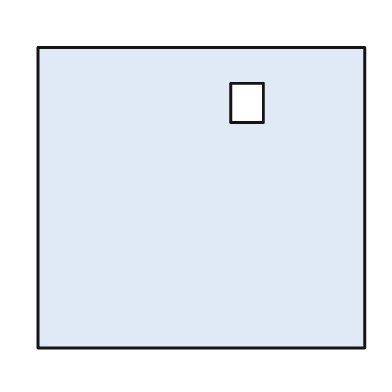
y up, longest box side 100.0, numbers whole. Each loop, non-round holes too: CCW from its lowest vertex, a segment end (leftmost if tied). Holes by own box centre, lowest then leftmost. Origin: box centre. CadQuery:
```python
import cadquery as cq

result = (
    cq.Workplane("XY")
    .moveTo(-50.0, -46.0)
    .lineTo(50.0, -46.0)
    .lineTo(50.0, 46.0)
    .lineTo(-50.0, 46.0)
    .close()
    .moveTo(9.0, 23.0)
    .lineTo(19.0, 23.0)
    .lineTo(19.0, 35.0)
    .lineTo(9.0, 35.0)
    .close()
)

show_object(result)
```